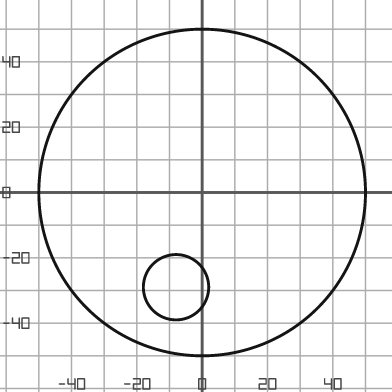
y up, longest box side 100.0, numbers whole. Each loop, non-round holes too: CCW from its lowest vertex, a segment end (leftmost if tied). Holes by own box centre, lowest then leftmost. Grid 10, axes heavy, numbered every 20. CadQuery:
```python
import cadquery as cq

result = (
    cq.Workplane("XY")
    .moveTo(0.0, 0.0)
    .circle(50.0)
    .moveTo(-8.0, -29.0)
    .circle(10.0)
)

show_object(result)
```